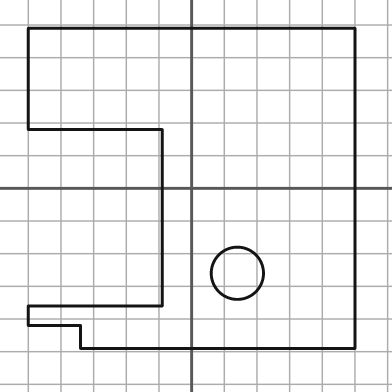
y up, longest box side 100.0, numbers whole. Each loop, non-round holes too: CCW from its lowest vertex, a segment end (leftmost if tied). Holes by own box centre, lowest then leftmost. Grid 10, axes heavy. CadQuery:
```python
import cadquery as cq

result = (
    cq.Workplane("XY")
    .moveTo(-34.0, -49.0)
    .lineTo(50.0, -49.0)
    .lineTo(50.0, 49.0)
    .lineTo(-50.0, 49.0)
    .lineTo(-50.0, 18.0)
    .lineTo(-9.0, 18.0)
    .lineTo(-9.0, -36.0)
    .lineTo(-50.0, -36.0)
    .lineTo(-50.0, -42.0)
    .lineTo(-34.0, -42.0)
    .close()
    .moveTo(14.0, -26.0)
    .circle(8.0)
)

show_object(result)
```